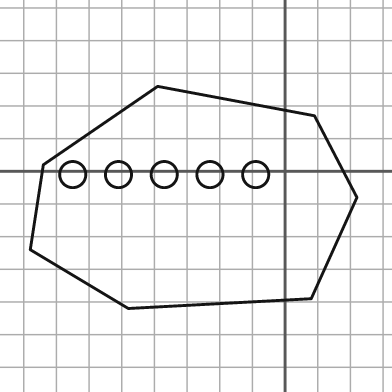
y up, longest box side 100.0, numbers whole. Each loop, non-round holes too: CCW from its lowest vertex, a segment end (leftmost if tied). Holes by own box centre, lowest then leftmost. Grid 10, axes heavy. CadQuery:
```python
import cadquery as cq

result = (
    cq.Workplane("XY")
    .moveTo(-48.0, -42.0)
    .lineTo(8.0, -39.0)
    .lineTo(22.0, -8.0)
    .lineTo(9.0, 17.0)
    .lineTo(-39.0, 26.0)
    .lineTo(-74.0, 2.0)
    .lineTo(-78.0, -24.0)
    .close()
    .moveTo(-65.0, -1.0)
    .circle(4.0)
    .moveTo(-51.0, -1.0)
    .circle(4.0)
    .moveTo(-37.0, -1.0)
    .circle(4.0)
    .moveTo(-23.0, -1.0)
    .circle(4.0)
    .moveTo(-9.0, -1.0)
    .circle(4.0)
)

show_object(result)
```